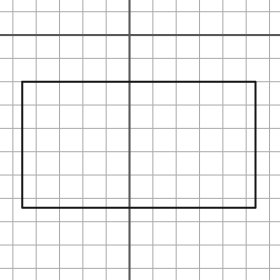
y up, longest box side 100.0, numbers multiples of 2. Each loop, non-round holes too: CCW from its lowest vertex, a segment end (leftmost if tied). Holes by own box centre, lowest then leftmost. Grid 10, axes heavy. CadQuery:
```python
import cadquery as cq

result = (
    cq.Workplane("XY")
    .moveTo(-46.0, -74.0)
    .lineTo(54.0, -74.0)
    .lineTo(54.0, -20.0)
    .lineTo(-46.0, -20.0)
    .close()
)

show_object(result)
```